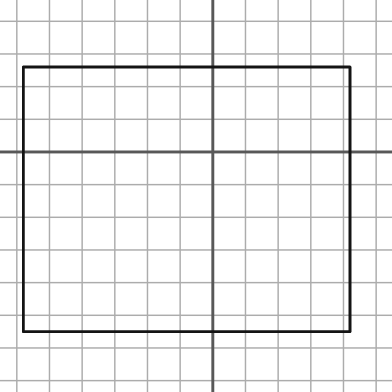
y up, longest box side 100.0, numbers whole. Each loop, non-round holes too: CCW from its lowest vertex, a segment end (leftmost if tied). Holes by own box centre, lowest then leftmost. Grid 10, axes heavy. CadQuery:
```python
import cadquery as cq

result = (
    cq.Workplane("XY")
    .moveTo(-58.0, -55.0)
    .lineTo(42.0, -55.0)
    .lineTo(42.0, 26.0)
    .lineTo(-58.0, 26.0)
    .close()
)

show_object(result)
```